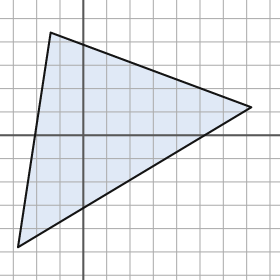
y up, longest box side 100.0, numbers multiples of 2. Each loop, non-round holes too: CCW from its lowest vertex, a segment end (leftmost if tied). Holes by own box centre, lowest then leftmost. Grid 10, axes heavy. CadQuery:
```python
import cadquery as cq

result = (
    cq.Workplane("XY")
    .moveTo(-28.0, -48.0)
    .lineTo(72.0, 12.0)
    .lineTo(-14.0, 44.0)
    .close()
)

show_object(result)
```